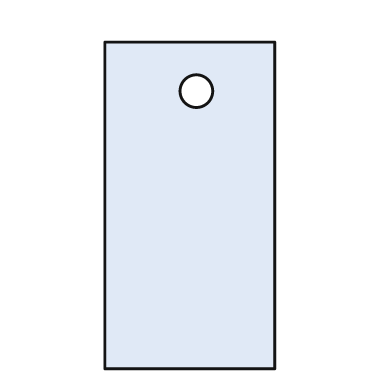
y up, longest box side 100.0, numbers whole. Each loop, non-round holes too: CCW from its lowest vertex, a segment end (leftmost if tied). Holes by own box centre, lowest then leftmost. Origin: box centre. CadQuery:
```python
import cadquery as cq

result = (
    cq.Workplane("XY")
    .moveTo(-26.0, -50.0)
    .lineTo(26.0, -50.0)
    .lineTo(26.0, 50.0)
    .lineTo(-26.0, 50.0)
    .close()
    .moveTo(2.0, 35.0)
    .circle(5.0)
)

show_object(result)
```